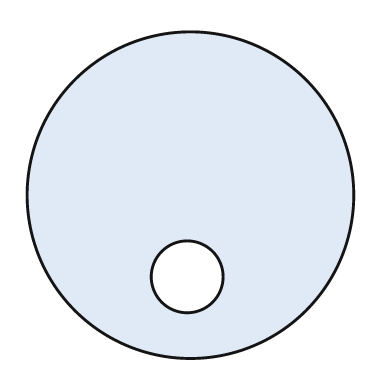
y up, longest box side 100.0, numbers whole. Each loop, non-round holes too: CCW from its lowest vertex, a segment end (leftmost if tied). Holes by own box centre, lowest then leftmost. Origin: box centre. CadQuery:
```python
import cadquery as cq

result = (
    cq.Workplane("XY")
    .moveTo(0.0, 0.0)
    .circle(50.0)
    .moveTo(-1.0, -25.0)
    .circle(11.0)
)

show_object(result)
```